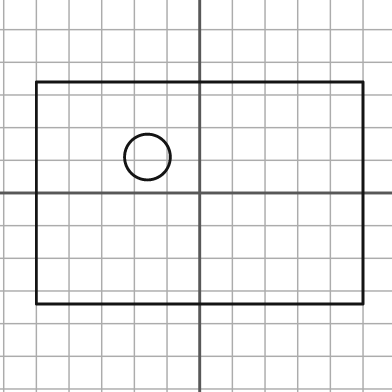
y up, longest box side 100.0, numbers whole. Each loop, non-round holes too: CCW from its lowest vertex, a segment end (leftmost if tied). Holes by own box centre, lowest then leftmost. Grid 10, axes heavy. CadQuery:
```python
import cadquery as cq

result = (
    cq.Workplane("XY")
    .moveTo(-50.0, -34.0)
    .lineTo(50.0, -34.0)
    .lineTo(50.0, 34.0)
    .lineTo(-50.0, 34.0)
    .close()
    .moveTo(-16.0, 11.0)
    .circle(7.0)
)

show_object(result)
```